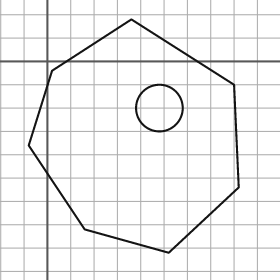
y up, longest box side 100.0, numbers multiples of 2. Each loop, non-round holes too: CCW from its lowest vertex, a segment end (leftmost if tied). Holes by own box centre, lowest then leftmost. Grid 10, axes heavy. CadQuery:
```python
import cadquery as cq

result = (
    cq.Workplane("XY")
    .moveTo(52.0, -82.0)
    .lineTo(82.0, -54.0)
    .lineTo(80.0, -10.0)
    .lineTo(36.0, 18.0)
    .lineTo(2.0, -4.0)
    .lineTo(-8.0, -36.0)
    .lineTo(16.0, -72.0)
    .close()
    .moveTo(48.0, -20.0)
    .circle(10.0)
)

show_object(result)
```